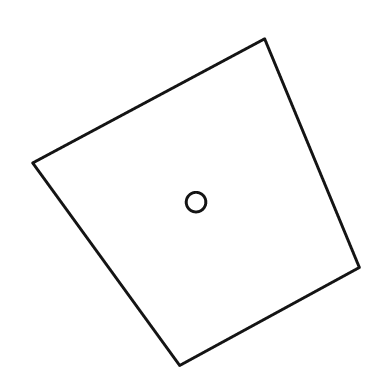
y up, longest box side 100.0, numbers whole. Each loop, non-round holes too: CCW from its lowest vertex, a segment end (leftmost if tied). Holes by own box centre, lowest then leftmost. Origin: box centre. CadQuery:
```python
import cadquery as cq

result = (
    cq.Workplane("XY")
    .moveTo(-5.0, -50.0)
    .lineTo(50.0, -20.0)
    .lineTo(21.0, 50.0)
    .lineTo(-50.0, 12.0)
    .close()
    .moveTo(0.0, 0.0)
    .circle(3.0)
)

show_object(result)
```